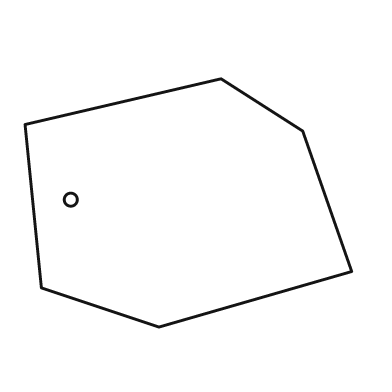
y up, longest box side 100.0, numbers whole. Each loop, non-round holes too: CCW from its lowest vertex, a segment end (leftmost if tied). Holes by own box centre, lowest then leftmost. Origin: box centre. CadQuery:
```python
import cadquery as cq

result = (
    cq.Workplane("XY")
    .moveTo(-9.0, -38.0)
    .lineTo(50.0, -21.0)
    .lineTo(35.0, 22.0)
    .lineTo(10.0, 38.0)
    .lineTo(-50.0, 24.0)
    .lineTo(-45.0, -26.0)
    .close()
    .moveTo(-36.0, 1.0)
    .circle(2.0)
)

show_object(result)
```